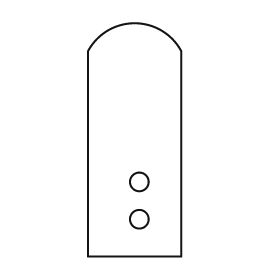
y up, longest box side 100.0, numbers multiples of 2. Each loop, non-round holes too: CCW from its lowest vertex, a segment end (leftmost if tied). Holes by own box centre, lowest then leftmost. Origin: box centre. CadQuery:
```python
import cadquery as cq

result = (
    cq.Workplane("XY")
    .moveTo(-20.0, -50.0)
    .lineTo(20.0, -50.0)
    .lineTo(20.0, 38.0)
    .threePointArc((0.0, 50.0), (-20.0, 38.0))
    .close()
    .moveTo(2.0, -34.0)
    .circle(4.0)
    .moveTo(2.0, -18.0)
    .circle(4.0)
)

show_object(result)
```